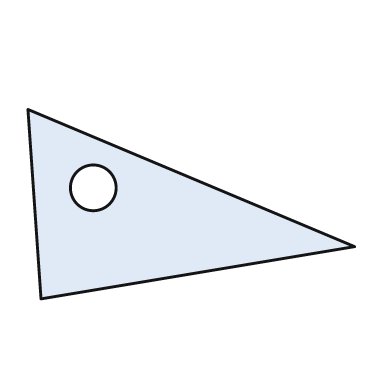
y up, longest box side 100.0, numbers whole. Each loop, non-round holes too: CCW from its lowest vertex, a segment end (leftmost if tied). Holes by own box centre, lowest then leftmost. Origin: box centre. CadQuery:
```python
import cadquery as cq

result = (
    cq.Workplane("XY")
    .moveTo(-46.0, -29.0)
    .lineTo(50.0, -13.0)
    .lineTo(-50.0, 29.0)
    .close()
    .moveTo(-30.0, 5.0)
    .circle(7.0)
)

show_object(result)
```